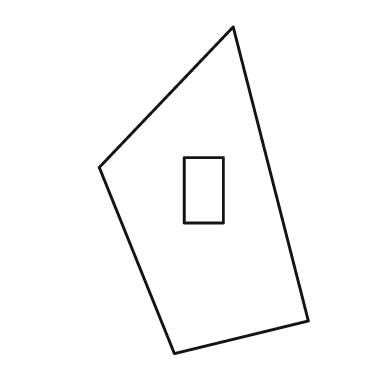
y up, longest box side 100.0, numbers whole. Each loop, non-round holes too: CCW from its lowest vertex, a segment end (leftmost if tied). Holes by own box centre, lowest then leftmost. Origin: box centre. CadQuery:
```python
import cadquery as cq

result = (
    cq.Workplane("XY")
    .moveTo(-9.0, -50.0)
    .lineTo(32.0, -40.0)
    .lineTo(9.0, 50.0)
    .lineTo(-32.0, 7.0)
    .close()
    .moveTo(-6.0, -10.0)
    .lineTo(6.0, -10.0)
    .lineTo(6.0, 10.0)
    .lineTo(-6.0, 10.0)
    .close()
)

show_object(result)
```